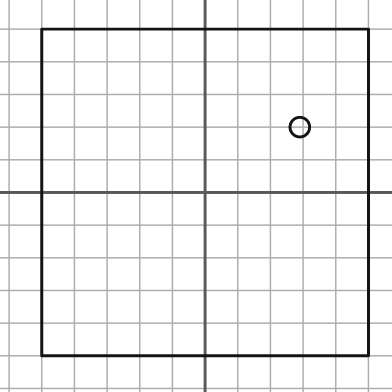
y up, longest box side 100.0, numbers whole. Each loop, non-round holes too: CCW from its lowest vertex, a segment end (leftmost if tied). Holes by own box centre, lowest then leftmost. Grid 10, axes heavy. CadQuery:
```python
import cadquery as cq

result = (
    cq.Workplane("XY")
    .moveTo(-50.0, -50.0)
    .lineTo(50.0, -50.0)
    .lineTo(50.0, 50.0)
    .lineTo(-50.0, 50.0)
    .close()
    .moveTo(29.0, 20.0)
    .circle(3.0)
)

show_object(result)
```